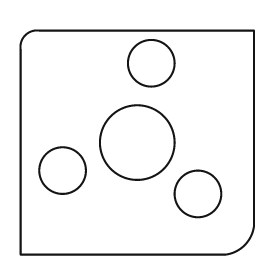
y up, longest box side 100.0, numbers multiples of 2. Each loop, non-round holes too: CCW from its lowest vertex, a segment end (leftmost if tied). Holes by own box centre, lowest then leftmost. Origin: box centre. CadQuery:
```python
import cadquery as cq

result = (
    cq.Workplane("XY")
    .moveTo(-50.0, -48.0)
    .lineTo(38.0, -48.0)
    .threePointArc((46.0, -44.0), (50.0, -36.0))
    .lineTo(50.0, 48.0)
    .lineTo(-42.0, 48.0)
    .threePointArc((-48.0, 46.0), (-50.0, 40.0))
    .close()
    .moveTo(26.0, -22.0)
    .circle(10.0)
    .moveTo(-32.0, -12.0)
    .circle(10.0)
    .moveTo(0.0, 0.0)
    .circle(16.0)
    .moveTo(6.0, 34.0)
    .circle(10.0)
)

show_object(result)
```